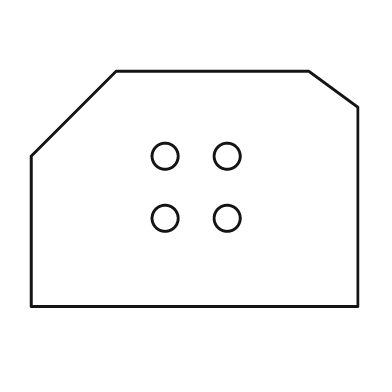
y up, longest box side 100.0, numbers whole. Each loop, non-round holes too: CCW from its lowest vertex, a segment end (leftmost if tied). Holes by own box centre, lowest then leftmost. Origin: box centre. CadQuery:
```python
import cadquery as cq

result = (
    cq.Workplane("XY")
    .moveTo(-50.0, -36.0)
    .lineTo(50.0, -36.0)
    .lineTo(50.0, 25.0)
    .lineTo(35.0, 36.0)
    .lineTo(-24.0, 36.0)
    .lineTo(-50.0, 10.0)
    .close()
    .moveTo(-9.0, -9.0)
    .circle(4.0)
    .moveTo(10.0, -9.0)
    .circle(4.0)
    .moveTo(-9.0, 10.0)
    .circle(4.0)
    .moveTo(10.0, 10.0)
    .circle(4.0)
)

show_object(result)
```